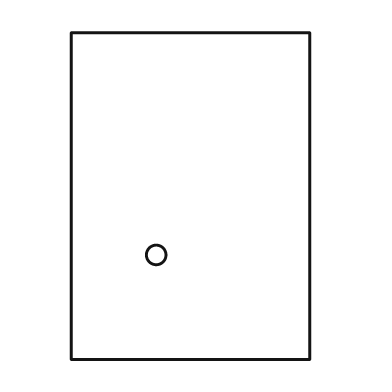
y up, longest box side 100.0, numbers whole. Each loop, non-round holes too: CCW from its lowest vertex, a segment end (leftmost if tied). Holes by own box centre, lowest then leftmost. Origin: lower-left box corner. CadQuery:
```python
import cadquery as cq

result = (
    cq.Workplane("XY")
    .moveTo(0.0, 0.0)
    .lineTo(73.0, 0.0)
    .lineTo(73.0, 100.0)
    .lineTo(0.0, 100.0)
    .close()
    .moveTo(26.0, 32.0)
    .circle(3.0)
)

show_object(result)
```